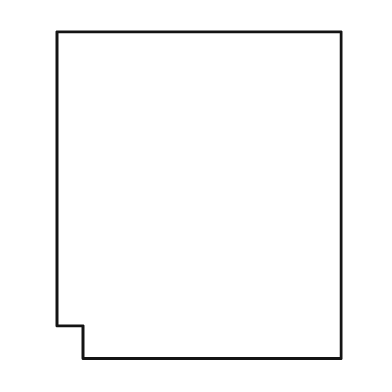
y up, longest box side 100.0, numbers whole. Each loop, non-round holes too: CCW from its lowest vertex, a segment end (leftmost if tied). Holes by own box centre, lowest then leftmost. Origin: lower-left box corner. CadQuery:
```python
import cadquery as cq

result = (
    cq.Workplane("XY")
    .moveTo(8.0, 0.0)
    .lineTo(87.0, 0.0)
    .lineTo(87.0, 100.0)
    .lineTo(0.0, 100.0)
    .lineTo(0.0, 10.0)
    .lineTo(8.0, 10.0)
    .close()
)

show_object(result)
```